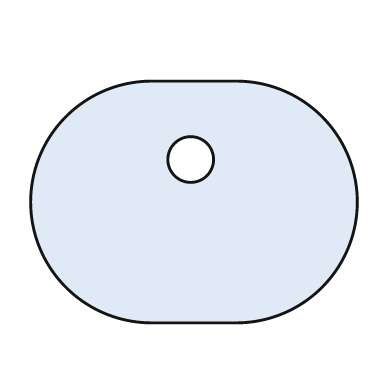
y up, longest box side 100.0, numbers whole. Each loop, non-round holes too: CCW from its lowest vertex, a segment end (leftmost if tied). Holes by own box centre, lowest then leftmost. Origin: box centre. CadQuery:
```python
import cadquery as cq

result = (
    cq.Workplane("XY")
    .moveTo(-13.0, -37.0)
    .lineTo(13.0, -37.0)
    .threePointArc((50.0, 0.0), (13.0, 37.0))
    .lineTo(-13.0, 37.0)
    .threePointArc((-50.0, 0.0), (-13.0, -37.0))
    .close()
    .moveTo(-1.0, 13.0)
    .circle(7.0)
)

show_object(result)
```